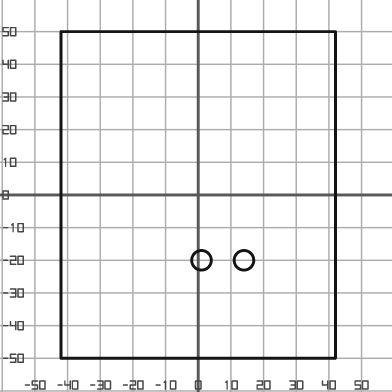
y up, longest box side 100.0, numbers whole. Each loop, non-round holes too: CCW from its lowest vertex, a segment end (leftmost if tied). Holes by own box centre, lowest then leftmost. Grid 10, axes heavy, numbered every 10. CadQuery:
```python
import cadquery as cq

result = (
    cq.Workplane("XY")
    .moveTo(-42.0, -50.0)
    .lineTo(42.0, -50.0)
    .lineTo(42.0, 50.0)
    .lineTo(-42.0, 50.0)
    .close()
    .moveTo(1.0, -20.0)
    .circle(3.0)
    .moveTo(14.0, -20.0)
    .circle(3.0)
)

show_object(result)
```